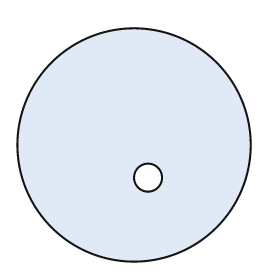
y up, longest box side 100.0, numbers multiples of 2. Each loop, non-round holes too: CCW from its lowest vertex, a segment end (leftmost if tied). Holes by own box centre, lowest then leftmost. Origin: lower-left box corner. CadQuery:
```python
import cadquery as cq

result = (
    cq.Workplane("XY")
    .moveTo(50.0, 50.0)
    .circle(50.0)
    .moveTo(56.0, 36.0)
    .circle(6.0)
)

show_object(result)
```